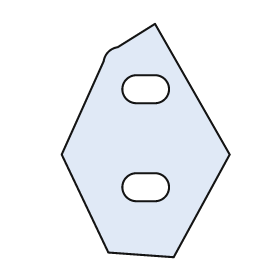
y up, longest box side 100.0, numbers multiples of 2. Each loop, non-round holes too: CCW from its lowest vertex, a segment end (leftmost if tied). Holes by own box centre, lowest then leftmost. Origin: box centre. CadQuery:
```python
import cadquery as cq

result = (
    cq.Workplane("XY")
    .moveTo(12.0, -50.0)
    .lineTo(36.0, -6.0)
    .lineTo(4.0, 50.0)
    .lineTo(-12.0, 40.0)
    .threePointArc((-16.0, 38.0), (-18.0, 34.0))
    .lineTo(-36.0, -6.0)
    .lineTo(-16.0, -48.0)
    .close()
    .moveTo(-4.0, -26.0)
    .lineTo(4.0, -26.0)
    .threePointArc((10.0, -20.0), (4.0, -14.0))
    .lineTo(-4.0, -14.0)
    .threePointArc((-10.0, -20.0), (-4.0, -26.0))
    .close()
    .moveTo(-4.0, 16.0)
    .lineTo(4.0, 16.0)
    .threePointArc((10.0, 22.0), (4.0, 28.0))
    .lineTo(-4.0, 28.0)
    .threePointArc((-10.0, 22.0), (-4.0, 16.0))
    .close()
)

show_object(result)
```